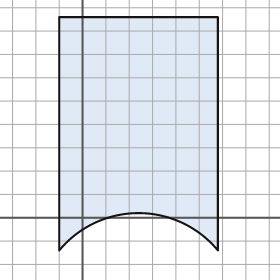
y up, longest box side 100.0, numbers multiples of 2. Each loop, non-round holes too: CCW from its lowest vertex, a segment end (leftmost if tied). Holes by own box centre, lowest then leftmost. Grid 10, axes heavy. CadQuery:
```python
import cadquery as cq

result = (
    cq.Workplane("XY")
    .moveTo(-10.0, -14.0)
    .threePointArc((24.0, 2.0), (58.0, -14.0))
    .lineTo(58.0, 86.0)
    .lineTo(-10.0, 86.0)
    .close()
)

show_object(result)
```